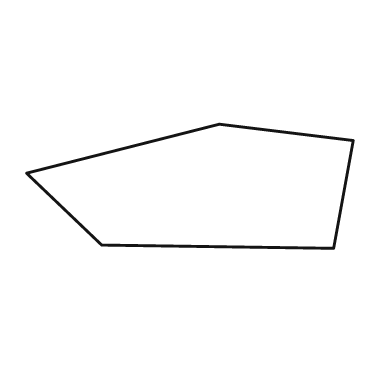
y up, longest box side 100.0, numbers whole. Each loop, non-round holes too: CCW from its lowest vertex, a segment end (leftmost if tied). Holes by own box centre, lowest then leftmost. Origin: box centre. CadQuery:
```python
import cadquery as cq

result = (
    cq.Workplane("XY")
    .moveTo(44.0, -19.0)
    .lineTo(50.0, 14.0)
    .lineTo(9.0, 19.0)
    .lineTo(-50.0, 4.0)
    .lineTo(-27.0, -18.0)
    .close()
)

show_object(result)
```